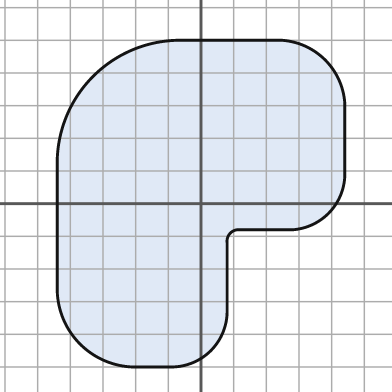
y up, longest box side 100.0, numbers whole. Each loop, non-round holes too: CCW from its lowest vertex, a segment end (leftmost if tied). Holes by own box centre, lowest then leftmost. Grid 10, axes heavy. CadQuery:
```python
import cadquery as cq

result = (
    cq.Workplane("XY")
    .moveTo(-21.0, -50.0)
    .lineTo(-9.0, -50.0)
    .threePointArc((3.0, -45.0), (8.0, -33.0))
    .lineTo(8.0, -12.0)
    .threePointArc((9.0, -9.0), (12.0, -8.0))
    .lineTo(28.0, -8.0)
    .threePointArc((39.0, -3.0), (44.0, 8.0))
    .lineTo(44.0, 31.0)
    .threePointArc((38.0, 44.0), (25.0, 50.0))
    .lineTo(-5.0, 50.0)
    .threePointArc((-33.0, 39.0), (-44.0, 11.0))
    .lineTo(-44.0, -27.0)
    .threePointArc((-37.0, -43.0), (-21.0, -50.0))
    .close()
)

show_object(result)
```